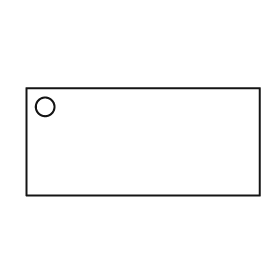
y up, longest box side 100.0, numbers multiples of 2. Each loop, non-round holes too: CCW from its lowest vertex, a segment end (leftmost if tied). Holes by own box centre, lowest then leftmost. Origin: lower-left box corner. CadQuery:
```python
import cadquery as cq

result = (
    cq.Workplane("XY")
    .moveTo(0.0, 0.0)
    .lineTo(100.0, 0.0)
    .lineTo(100.0, 46.0)
    .lineTo(0.0, 46.0)
    .close()
    .moveTo(8.0, 38.0)
    .circle(4.0)
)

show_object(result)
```